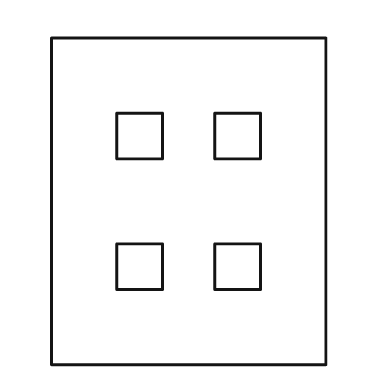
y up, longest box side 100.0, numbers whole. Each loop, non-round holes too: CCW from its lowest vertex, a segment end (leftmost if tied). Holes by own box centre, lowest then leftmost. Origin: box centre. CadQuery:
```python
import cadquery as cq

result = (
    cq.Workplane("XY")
    .moveTo(-42.0, -50.0)
    .lineTo(42.0, -50.0)
    .lineTo(42.0, 50.0)
    .lineTo(-42.0, 50.0)
    .close()
    .moveTo(-22.0, -27.0)
    .lineTo(-8.0, -27.0)
    .lineTo(-8.0, -13.0)
    .lineTo(-22.0, -13.0)
    .close()
    .moveTo(8.0, -27.0)
    .lineTo(22.0, -27.0)
    .lineTo(22.0, -13.0)
    .lineTo(8.0, -13.0)
    .close()
    .moveTo(-22.0, 13.0)
    .lineTo(-8.0, 13.0)
    .lineTo(-8.0, 27.0)
    .lineTo(-22.0, 27.0)
    .close()
    .moveTo(8.0, 13.0)
    .lineTo(22.0, 13.0)
    .lineTo(22.0, 27.0)
    .lineTo(8.0, 27.0)
    .close()
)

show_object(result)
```